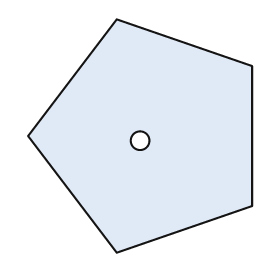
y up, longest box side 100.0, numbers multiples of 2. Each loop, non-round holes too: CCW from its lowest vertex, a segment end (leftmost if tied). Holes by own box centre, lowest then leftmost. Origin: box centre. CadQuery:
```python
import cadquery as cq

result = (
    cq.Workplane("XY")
    .moveTo(-10.0, -50.0)
    .lineTo(48.0, -30.0)
    .lineTo(48.0, 30.0)
    .lineTo(-10.0, 50.0)
    .lineTo(-48.0, 0.0)
    .close()
    .moveTo(0.0, -2.0)
    .circle(4.0)
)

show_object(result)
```